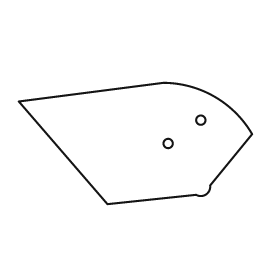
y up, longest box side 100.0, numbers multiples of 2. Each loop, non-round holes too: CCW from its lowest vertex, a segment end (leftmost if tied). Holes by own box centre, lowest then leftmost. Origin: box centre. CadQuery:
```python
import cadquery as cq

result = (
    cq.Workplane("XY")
    .moveTo(-12.0, -26.0)
    .lineTo(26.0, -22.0)
    .threePointArc((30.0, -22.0), (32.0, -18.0))
    .lineTo(50.0, 4.0)
    .threePointArc((34.0, 20.0), (12.0, 26.0))
    .lineTo(-50.0, 18.0)
    .close()
    .moveTo(14.0, 0.0)
    .circle(2.0)
    .moveTo(28.0, 10.0)
    .circle(2.0)
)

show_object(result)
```